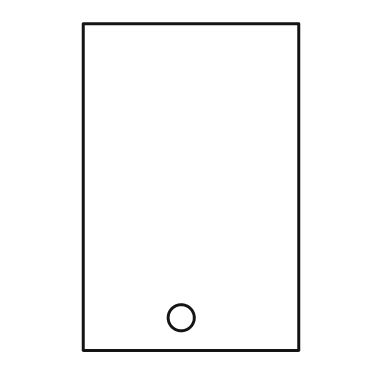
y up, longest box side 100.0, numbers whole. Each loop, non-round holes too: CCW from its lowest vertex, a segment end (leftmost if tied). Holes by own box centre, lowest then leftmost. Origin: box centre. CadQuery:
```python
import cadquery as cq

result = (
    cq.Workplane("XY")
    .moveTo(-33.0, -50.0)
    .lineTo(33.0, -50.0)
    .lineTo(33.0, 50.0)
    .lineTo(-33.0, 50.0)
    .close()
    .moveTo(-3.0, -40.0)
    .circle(4.0)
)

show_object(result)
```